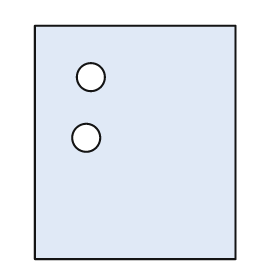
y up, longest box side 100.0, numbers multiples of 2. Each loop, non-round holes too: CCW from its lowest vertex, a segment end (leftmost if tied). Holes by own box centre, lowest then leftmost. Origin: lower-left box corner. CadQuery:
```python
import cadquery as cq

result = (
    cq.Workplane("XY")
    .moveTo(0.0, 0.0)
    .lineTo(86.0, 0.0)
    .lineTo(86.0, 100.0)
    .lineTo(0.0, 100.0)
    .close()
    .moveTo(22.0, 52.0)
    .circle(6.0)
    .moveTo(24.0, 78.0)
    .circle(6.0)
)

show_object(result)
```